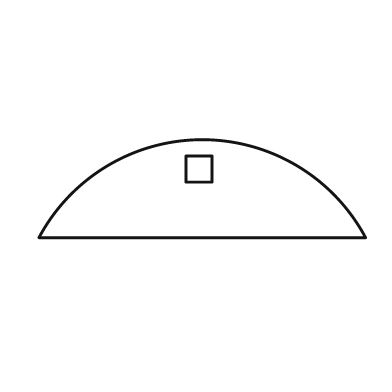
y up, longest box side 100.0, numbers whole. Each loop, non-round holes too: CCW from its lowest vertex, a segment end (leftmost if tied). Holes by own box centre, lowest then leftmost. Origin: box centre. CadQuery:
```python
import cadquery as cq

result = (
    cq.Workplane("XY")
    .moveTo(-50.0, -15.0)
    .lineTo(50.0, -15.0)
    .threePointArc((0.0, 15.0), (-50.0, -15.0))
    .close()
    .moveTo(-5.0, 2.0)
    .lineTo(3.0, 2.0)
    .lineTo(3.0, 10.0)
    .lineTo(-5.0, 10.0)
    .close()
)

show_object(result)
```